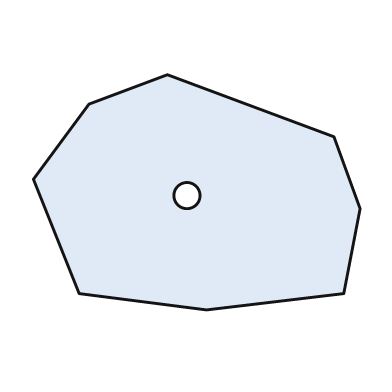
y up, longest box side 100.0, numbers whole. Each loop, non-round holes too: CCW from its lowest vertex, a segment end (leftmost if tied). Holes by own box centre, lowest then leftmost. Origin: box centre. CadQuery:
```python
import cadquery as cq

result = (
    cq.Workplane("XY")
    .moveTo(3.0, -36.0)
    .lineTo(45.0, -31.0)
    .lineTo(50.0, -5.0)
    .lineTo(42.0, 17.0)
    .lineTo(-9.0, 36.0)
    .lineTo(-33.0, 27.0)
    .lineTo(-50.0, 4.0)
    .lineTo(-36.0, -31.0)
    .close()
    .moveTo(-3.0, -1.0)
    .circle(4.0)
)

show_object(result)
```